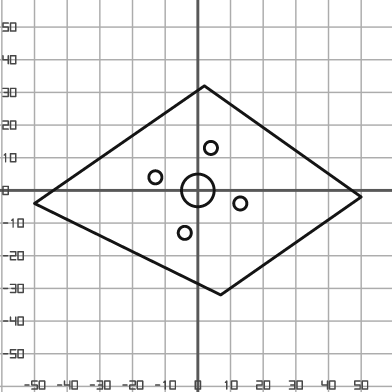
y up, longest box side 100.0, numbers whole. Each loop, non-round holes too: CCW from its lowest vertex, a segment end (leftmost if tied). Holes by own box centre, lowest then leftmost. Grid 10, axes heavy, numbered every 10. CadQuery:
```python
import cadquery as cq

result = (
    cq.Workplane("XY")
    .moveTo(7.0, -32.0)
    .lineTo(50.0, -2.0)
    .lineTo(2.0, 32.0)
    .lineTo(-50.0, -4.0)
    .close()
    .moveTo(-4.0, -13.0)
    .circle(2.0)
    .moveTo(13.0, -4.0)
    .circle(2.0)
    .moveTo(0.0, 0.0)
    .circle(5.0)
    .moveTo(-13.0, 4.0)
    .circle(2.0)
    .moveTo(4.0, 13.0)
    .circle(2.0)
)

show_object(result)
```